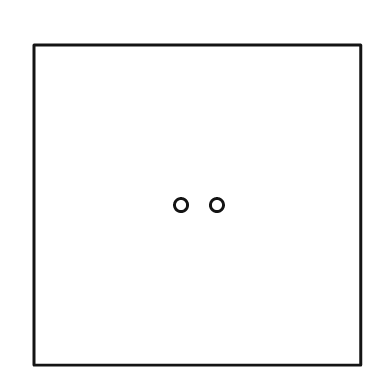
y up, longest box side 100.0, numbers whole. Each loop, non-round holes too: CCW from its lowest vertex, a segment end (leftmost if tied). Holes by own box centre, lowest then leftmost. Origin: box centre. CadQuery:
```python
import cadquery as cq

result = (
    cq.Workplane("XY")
    .moveTo(-50.0, -49.0)
    .lineTo(50.0, -49.0)
    .lineTo(50.0, 49.0)
    .lineTo(-50.0, 49.0)
    .close()
    .moveTo(-5.0, 0.0)
    .circle(2.0)
    .moveTo(6.0, 0.0)
    .circle(2.0)
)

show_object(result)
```